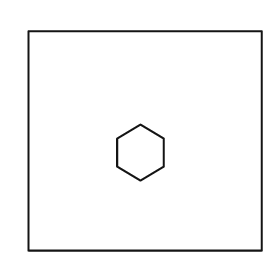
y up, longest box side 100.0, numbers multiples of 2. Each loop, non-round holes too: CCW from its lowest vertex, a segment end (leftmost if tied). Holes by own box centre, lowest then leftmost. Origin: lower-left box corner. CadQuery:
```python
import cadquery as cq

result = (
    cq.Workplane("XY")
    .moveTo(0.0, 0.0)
    .lineTo(100.0, 0.0)
    .lineTo(100.0, 94.0)
    .lineTo(0.0, 94.0)
    .close()
    .moveTo(48.0, 30.0)
    .lineTo(58.0, 36.0)
    .lineTo(58.0, 48.0)
    .lineTo(48.0, 54.0)
    .lineTo(38.0, 48.0)
    .lineTo(38.0, 36.0)
    .close()
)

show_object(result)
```